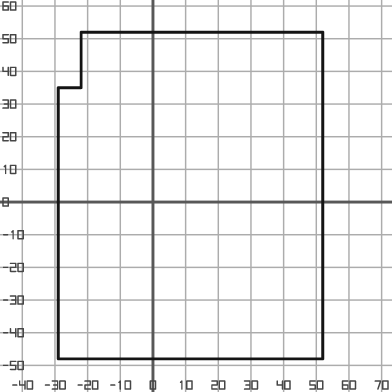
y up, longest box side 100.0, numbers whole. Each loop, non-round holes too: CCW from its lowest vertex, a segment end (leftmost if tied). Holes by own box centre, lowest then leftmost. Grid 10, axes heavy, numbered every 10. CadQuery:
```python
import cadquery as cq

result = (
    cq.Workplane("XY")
    .moveTo(-29.0, -48.0)
    .lineTo(52.0, -48.0)
    .lineTo(52.0, 52.0)
    .lineTo(-22.0, 52.0)
    .lineTo(-22.0, 35.0)
    .lineTo(-29.0, 35.0)
    .close()
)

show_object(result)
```